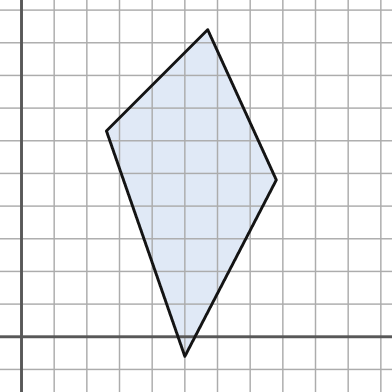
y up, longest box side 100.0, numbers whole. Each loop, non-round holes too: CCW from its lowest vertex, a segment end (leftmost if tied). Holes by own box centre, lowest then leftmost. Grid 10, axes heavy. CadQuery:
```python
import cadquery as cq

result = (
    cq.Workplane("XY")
    .moveTo(50.0, -6.0)
    .lineTo(78.0, 48.0)
    .lineTo(57.0, 94.0)
    .lineTo(26.0, 63.0)
    .close()
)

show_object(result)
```